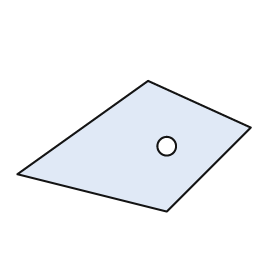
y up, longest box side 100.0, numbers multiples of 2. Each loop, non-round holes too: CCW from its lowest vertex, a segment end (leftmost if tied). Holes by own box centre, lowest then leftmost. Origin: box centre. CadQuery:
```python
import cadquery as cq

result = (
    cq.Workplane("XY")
    .moveTo(14.0, -28.0)
    .lineTo(50.0, 8.0)
    .lineTo(6.0, 28.0)
    .lineTo(-50.0, -12.0)
    .close()
    .moveTo(14.0, 0.0)
    .circle(4.0)
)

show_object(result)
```